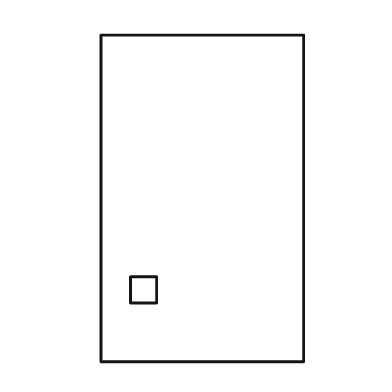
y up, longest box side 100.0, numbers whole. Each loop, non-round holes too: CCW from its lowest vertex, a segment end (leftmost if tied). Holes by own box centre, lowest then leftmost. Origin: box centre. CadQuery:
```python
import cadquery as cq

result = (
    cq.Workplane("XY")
    .moveTo(-31.0, -50.0)
    .lineTo(31.0, -50.0)
    .lineTo(31.0, 50.0)
    .lineTo(-31.0, 50.0)
    .close()
    .moveTo(-22.0, -32.0)
    .lineTo(-14.0, -32.0)
    .lineTo(-14.0, -24.0)
    .lineTo(-22.0, -24.0)
    .close()
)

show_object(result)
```